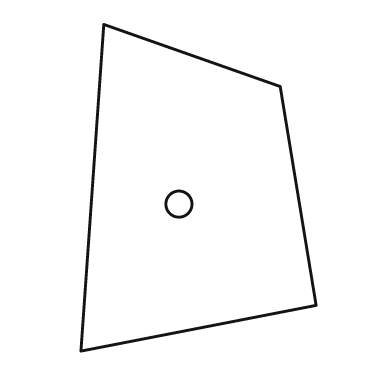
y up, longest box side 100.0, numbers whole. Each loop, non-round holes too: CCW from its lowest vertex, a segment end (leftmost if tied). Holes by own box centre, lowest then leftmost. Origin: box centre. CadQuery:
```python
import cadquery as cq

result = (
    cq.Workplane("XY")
    .moveTo(-36.0, -50.0)
    .lineTo(36.0, -36.0)
    .lineTo(25.0, 31.0)
    .lineTo(-29.0, 50.0)
    .close()
    .moveTo(-6.0, -5.0)
    .circle(4.0)
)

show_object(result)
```